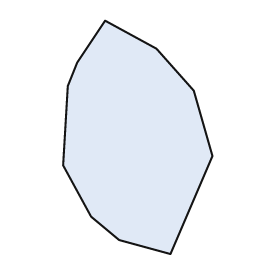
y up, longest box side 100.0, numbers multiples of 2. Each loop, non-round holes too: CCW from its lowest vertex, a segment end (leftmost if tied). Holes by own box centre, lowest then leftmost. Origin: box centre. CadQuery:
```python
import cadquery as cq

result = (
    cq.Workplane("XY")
    .moveTo(14.0, -50.0)
    .lineTo(32.0, -8.0)
    .lineTo(24.0, 20.0)
    .lineTo(8.0, 38.0)
    .lineTo(-14.0, 50.0)
    .lineTo(-26.0, 32.0)
    .lineTo(-30.0, 22.0)
    .lineTo(-32.0, -12.0)
    .lineTo(-20.0, -34.0)
    .lineTo(-8.0, -44.0)
    .close()
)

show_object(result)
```